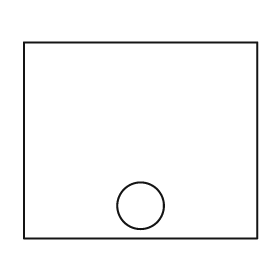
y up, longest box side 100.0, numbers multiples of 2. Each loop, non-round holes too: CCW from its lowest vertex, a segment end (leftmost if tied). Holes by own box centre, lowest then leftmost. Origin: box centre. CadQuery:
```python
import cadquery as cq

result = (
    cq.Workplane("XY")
    .moveTo(-50.0, -42.0)
    .lineTo(50.0, -42.0)
    .lineTo(50.0, 42.0)
    .lineTo(-50.0, 42.0)
    .close()
    .moveTo(0.0, -28.0)
    .circle(10.0)
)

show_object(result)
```